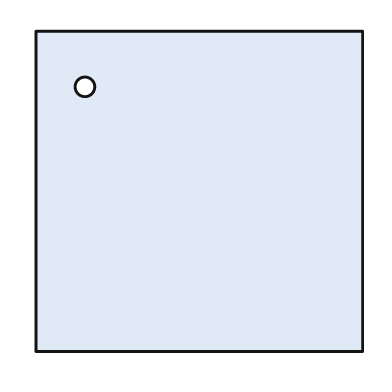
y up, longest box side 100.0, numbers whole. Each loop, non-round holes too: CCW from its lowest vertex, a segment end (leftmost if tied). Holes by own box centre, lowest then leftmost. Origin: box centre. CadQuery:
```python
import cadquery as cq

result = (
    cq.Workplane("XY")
    .moveTo(-50.0, -49.0)
    .lineTo(50.0, -49.0)
    .lineTo(50.0, 49.0)
    .lineTo(-50.0, 49.0)
    .close()
    .moveTo(-35.0, 32.0)
    .circle(3.0)
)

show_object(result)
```